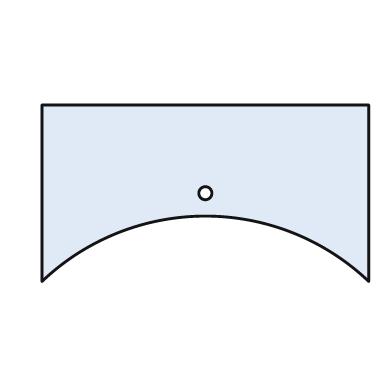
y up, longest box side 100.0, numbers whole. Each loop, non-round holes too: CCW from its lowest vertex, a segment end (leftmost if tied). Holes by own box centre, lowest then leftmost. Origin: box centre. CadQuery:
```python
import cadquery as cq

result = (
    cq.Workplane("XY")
    .moveTo(-50.0, -27.0)
    .threePointArc((0.0, -7.0), (50.0, -27.0))
    .lineTo(50.0, 27.0)
    .lineTo(-50.0, 27.0)
    .close()
    .moveTo(0.0, 0.0)
    .circle(2.0)
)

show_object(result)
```